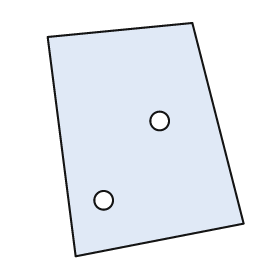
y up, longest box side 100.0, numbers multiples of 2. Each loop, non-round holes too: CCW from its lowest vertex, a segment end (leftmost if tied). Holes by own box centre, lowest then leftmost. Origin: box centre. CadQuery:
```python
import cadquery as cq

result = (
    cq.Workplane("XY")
    .moveTo(-30.0, -50.0)
    .lineTo(42.0, -36.0)
    .lineTo(20.0, 50.0)
    .lineTo(-42.0, 44.0)
    .close()
    .moveTo(-18.0, -26.0)
    .circle(4.0)
    .moveTo(6.0, 8.0)
    .circle(4.0)
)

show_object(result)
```